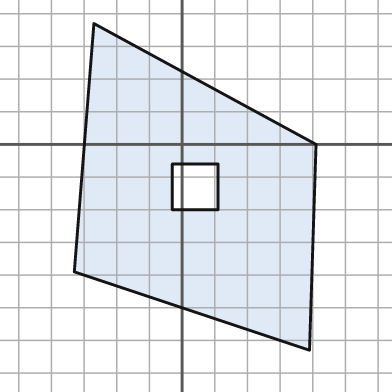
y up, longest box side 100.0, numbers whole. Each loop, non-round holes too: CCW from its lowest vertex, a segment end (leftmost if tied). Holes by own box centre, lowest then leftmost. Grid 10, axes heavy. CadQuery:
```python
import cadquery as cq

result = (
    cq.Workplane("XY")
    .moveTo(39.0, -63.0)
    .lineTo(41.0, 0.0)
    .lineTo(-27.0, 37.0)
    .lineTo(-33.0, -39.0)
    .close()
    .moveTo(-3.0, -20.0)
    .lineTo(11.0, -20.0)
    .lineTo(11.0, -6.0)
    .lineTo(-3.0, -6.0)
    .close()
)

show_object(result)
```